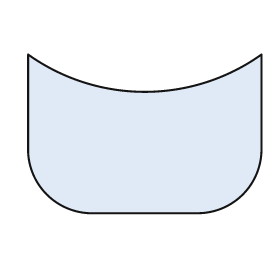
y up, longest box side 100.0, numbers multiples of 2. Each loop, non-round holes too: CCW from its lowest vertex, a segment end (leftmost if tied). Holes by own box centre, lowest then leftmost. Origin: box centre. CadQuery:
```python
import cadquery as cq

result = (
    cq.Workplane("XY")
    .moveTo(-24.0, -34.0)
    .lineTo(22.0, -34.0)
    .threePointArc((42.0, -26.0), (50.0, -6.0))
    .lineTo(50.0, 34.0)
    .threePointArc((0.0, 18.0), (-50.0, 34.0))
    .lineTo(-50.0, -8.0)
    .threePointArc((-42.0, -26.0), (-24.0, -34.0))
    .close()
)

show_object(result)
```